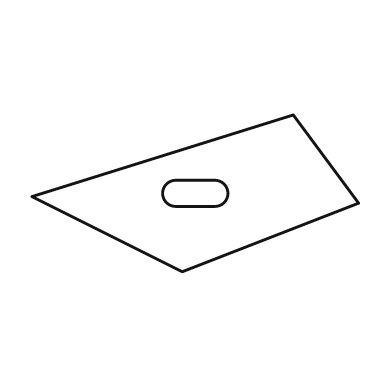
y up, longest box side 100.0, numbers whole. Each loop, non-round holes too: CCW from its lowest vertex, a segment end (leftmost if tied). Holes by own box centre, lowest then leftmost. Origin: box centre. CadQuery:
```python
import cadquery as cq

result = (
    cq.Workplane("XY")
    .moveTo(-4.0, -24.0)
    .lineTo(50.0, -3.0)
    .lineTo(30.0, 24.0)
    .lineTo(-50.0, -1.0)
    .close()
    .moveTo(-6.0, -4.0)
    .lineTo(6.0, -4.0)
    .threePointArc((10.0, 0.0), (6.0, 4.0))
    .lineTo(-6.0, 4.0)
    .threePointArc((-10.0, 0.0), (-6.0, -4.0))
    .close()
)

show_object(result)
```